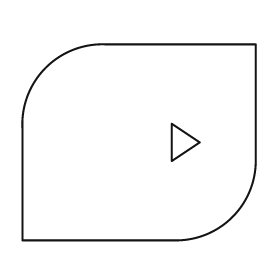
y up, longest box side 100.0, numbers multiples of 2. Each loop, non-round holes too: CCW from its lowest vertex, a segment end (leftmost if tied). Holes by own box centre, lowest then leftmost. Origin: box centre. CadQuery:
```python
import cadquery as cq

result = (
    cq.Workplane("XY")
    .moveTo(-50.0, -42.0)
    .lineTo(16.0, -42.0)
    .threePointArc((40.0, -32.0), (50.0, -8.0))
    .lineTo(50.0, 42.0)
    .lineTo(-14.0, 42.0)
    .threePointArc((-40.0, 32.0), (-50.0, 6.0))
    .close()
    .moveTo(14.0, -8.0)
    .lineTo(26.0, 0.0)
    .lineTo(14.0, 8.0)
    .close()
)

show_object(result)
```